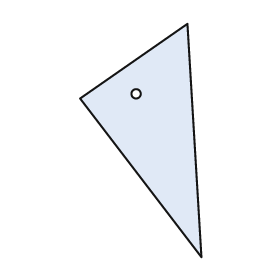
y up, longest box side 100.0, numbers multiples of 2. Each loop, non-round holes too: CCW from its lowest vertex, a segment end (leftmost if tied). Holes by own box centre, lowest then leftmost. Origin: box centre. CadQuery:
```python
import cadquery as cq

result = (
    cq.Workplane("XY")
    .moveTo(26.0, -50.0)
    .lineTo(20.0, 50.0)
    .lineTo(-26.0, 18.0)
    .close()
    .moveTo(-2.0, 20.0)
    .circle(2.0)
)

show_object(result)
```